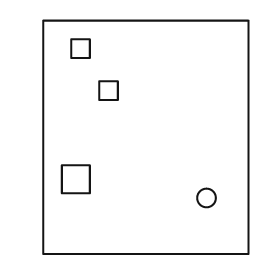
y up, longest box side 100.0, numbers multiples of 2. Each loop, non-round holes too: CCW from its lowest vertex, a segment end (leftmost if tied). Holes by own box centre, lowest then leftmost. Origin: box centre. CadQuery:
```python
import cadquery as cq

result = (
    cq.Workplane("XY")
    .moveTo(-44.0, -50.0)
    .lineTo(44.0, -50.0)
    .lineTo(44.0, 50.0)
    .lineTo(-44.0, 50.0)
    .close()
    .moveTo(26.0, -26.0)
    .circle(4.0)
    .moveTo(-36.0, -24.0)
    .lineTo(-24.0, -24.0)
    .lineTo(-24.0, -12.0)
    .lineTo(-36.0, -12.0)
    .close()
    .moveTo(-20.0, 16.0)
    .lineTo(-12.0, 16.0)
    .lineTo(-12.0, 24.0)
    .lineTo(-20.0, 24.0)
    .close()
    .moveTo(-32.0, 34.0)
    .lineTo(-24.0, 34.0)
    .lineTo(-24.0, 42.0)
    .lineTo(-32.0, 42.0)
    .close()
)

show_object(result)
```